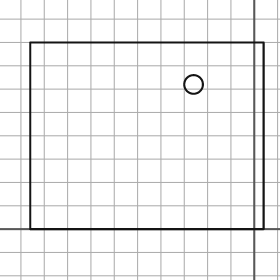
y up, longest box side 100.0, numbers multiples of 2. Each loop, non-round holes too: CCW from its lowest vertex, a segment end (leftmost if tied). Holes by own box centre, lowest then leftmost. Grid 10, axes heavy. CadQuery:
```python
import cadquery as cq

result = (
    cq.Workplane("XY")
    .moveTo(-96.0, 0.0)
    .lineTo(4.0, 0.0)
    .lineTo(4.0, 80.0)
    .lineTo(-96.0, 80.0)
    .close()
    .moveTo(-26.0, 62.0)
    .circle(4.0)
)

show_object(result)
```